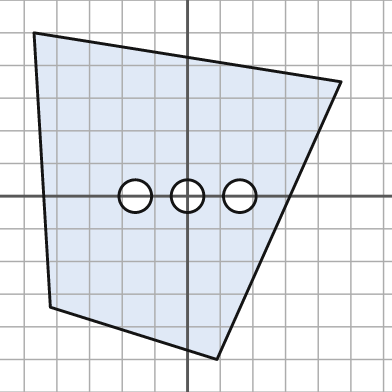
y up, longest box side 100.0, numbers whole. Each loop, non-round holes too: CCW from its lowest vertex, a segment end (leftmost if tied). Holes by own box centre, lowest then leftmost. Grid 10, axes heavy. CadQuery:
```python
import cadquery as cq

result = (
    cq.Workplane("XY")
    .moveTo(9.0, -50.0)
    .lineTo(47.0, 35.0)
    .lineTo(-47.0, 50.0)
    .lineTo(-42.0, -34.0)
    .close()
    .moveTo(-16.0, 0.0)
    .circle(5.0)
    .moveTo(0.0, 0.0)
    .circle(5.0)
    .moveTo(16.0, 0.0)
    .circle(5.0)
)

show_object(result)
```